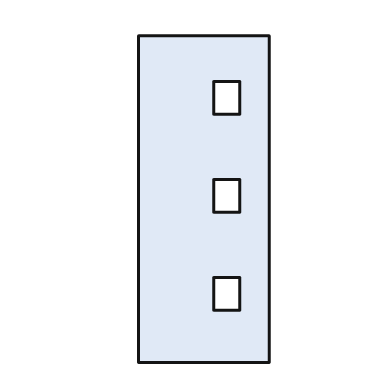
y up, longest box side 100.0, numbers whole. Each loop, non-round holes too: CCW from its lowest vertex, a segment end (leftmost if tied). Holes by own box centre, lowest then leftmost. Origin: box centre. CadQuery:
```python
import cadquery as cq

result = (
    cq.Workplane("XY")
    .moveTo(-20.0, -50.0)
    .lineTo(20.0, -50.0)
    .lineTo(20.0, 50.0)
    .lineTo(-20.0, 50.0)
    .close()
    .moveTo(3.0, -34.0)
    .lineTo(11.0, -34.0)
    .lineTo(11.0, -24.0)
    .lineTo(3.0, -24.0)
    .close()
    .moveTo(3.0, -4.0)
    .lineTo(11.0, -4.0)
    .lineTo(11.0, 6.0)
    .lineTo(3.0, 6.0)
    .close()
    .moveTo(3.0, 26.0)
    .lineTo(11.0, 26.0)
    .lineTo(11.0, 36.0)
    .lineTo(3.0, 36.0)
    .close()
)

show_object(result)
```